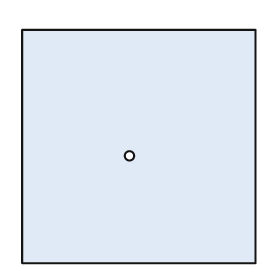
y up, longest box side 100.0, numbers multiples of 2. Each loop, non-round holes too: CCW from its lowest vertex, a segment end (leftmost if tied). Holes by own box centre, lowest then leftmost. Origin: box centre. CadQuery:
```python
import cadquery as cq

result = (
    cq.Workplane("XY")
    .moveTo(-50.0, -50.0)
    .lineTo(50.0, -50.0)
    .lineTo(50.0, 50.0)
    .lineTo(-50.0, 50.0)
    .close()
    .moveTo(-4.0, -4.0)
    .circle(2.0)
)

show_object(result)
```